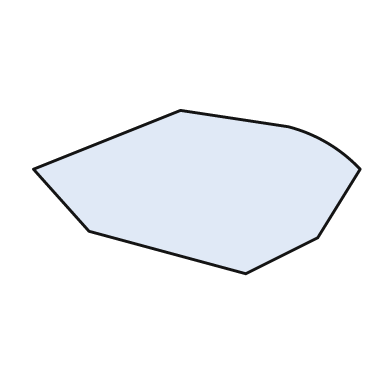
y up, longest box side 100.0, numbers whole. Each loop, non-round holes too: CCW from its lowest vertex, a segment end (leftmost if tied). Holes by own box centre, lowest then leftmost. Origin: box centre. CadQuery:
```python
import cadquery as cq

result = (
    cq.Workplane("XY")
    .moveTo(15.0, -25.0)
    .lineTo(37.0, -14.0)
    .lineTo(50.0, 7.0)
    .threePointArc((40.0, 15.0), (28.0, 20.0))
    .lineTo(-5.0, 25.0)
    .lineTo(-50.0, 7.0)
    .lineTo(-33.0, -12.0)
    .close()
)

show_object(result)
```